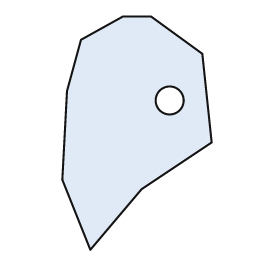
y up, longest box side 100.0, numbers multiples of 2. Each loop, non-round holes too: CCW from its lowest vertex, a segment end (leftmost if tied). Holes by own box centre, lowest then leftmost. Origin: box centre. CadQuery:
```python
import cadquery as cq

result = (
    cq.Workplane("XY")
    .moveTo(-20.0, -50.0)
    .lineTo(2.0, -24.0)
    .lineTo(32.0, -4.0)
    .lineTo(28.0, 34.0)
    .lineTo(6.0, 50.0)
    .lineTo(-6.0, 50.0)
    .lineTo(-24.0, 40.0)
    .lineTo(-30.0, 18.0)
    .lineTo(-32.0, -20.0)
    .close()
    .moveTo(14.0, 14.0)
    .circle(6.0)
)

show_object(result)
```